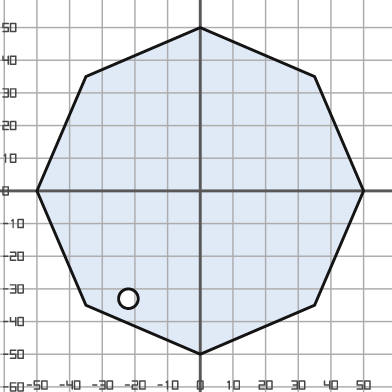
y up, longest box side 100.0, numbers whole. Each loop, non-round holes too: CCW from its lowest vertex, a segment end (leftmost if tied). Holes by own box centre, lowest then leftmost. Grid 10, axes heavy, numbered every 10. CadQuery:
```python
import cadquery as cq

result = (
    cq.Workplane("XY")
    .moveTo(0.0, -50.0)
    .lineTo(35.0, -35.0)
    .lineTo(50.0, 0.0)
    .lineTo(35.0, 35.0)
    .lineTo(0.0, 50.0)
    .lineTo(-35.0, 35.0)
    .lineTo(-50.0, 0.0)
    .lineTo(-35.0, -35.0)
    .close()
    .moveTo(-22.0, -33.0)
    .circle(3.0)
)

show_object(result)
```